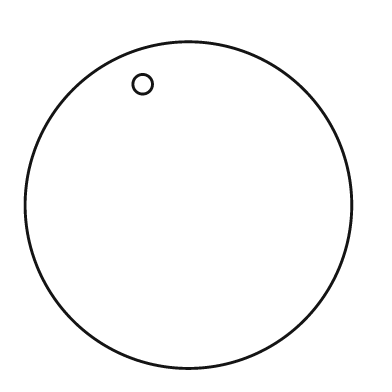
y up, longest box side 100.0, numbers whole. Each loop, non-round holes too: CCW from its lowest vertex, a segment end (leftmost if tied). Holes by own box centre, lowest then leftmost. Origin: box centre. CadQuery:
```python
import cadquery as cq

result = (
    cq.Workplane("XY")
    .moveTo(0.0, 0.0)
    .circle(50.0)
    .moveTo(-14.0, 37.0)
    .circle(3.0)
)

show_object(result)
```